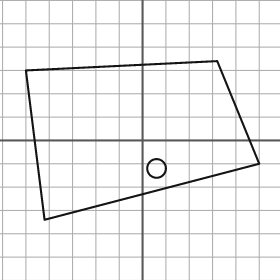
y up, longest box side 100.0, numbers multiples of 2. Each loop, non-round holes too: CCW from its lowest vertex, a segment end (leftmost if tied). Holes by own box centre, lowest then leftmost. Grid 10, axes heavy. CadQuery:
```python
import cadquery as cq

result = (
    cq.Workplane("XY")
    .moveTo(-42.0, -34.0)
    .lineTo(50.0, -10.0)
    .lineTo(32.0, 34.0)
    .lineTo(-50.0, 30.0)
    .close()
    .moveTo(6.0, -12.0)
    .circle(4.0)
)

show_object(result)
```